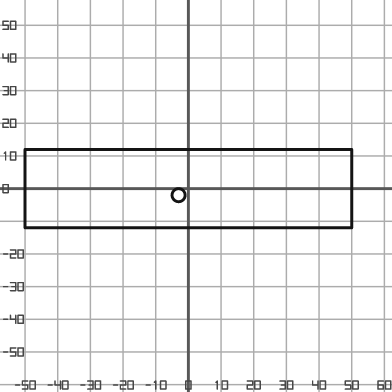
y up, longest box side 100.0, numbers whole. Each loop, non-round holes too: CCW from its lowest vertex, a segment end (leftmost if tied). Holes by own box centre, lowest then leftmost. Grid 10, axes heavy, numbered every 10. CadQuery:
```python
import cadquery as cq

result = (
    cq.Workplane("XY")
    .moveTo(-50.0, -12.0)
    .lineTo(50.0, -12.0)
    .lineTo(50.0, 12.0)
    .lineTo(-50.0, 12.0)
    .close()
    .moveTo(-3.0, -2.0)
    .circle(2.0)
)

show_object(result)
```